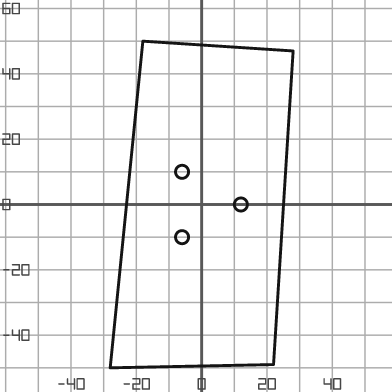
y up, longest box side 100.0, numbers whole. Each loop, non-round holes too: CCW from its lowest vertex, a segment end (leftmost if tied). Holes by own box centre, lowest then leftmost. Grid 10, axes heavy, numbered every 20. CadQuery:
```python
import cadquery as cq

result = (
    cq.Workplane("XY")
    .moveTo(-28.0, -50.0)
    .lineTo(22.0, -49.0)
    .lineTo(28.0, 47.0)
    .lineTo(-18.0, 50.0)
    .close()
    .moveTo(-6.0, -10.0)
    .circle(2.0)
    .moveTo(12.0, 0.0)
    .circle(2.0)
    .moveTo(-6.0, 10.0)
    .circle(2.0)
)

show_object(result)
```